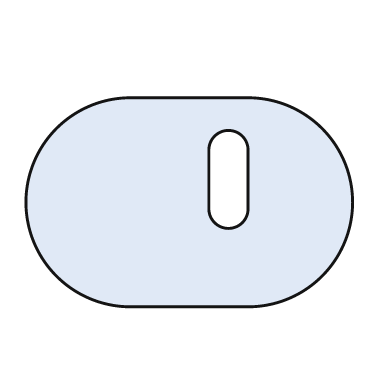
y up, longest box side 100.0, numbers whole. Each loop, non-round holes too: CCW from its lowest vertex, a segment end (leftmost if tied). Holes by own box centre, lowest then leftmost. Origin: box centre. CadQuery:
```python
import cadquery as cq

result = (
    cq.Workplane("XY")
    .moveTo(-18.0, -32.0)
    .lineTo(18.0, -32.0)
    .threePointArc((50.0, 0.0), (18.0, 32.0))
    .lineTo(-18.0, 32.0)
    .threePointArc((-50.0, 0.0), (-18.0, -32.0))
    .close()
    .moveTo(6.0, -2.0)
    .threePointArc((12.0, -8.0), (18.0, -2.0))
    .lineTo(18.0, 16.0)
    .threePointArc((12.0, 22.0), (6.0, 16.0))
    .close()
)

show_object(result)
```